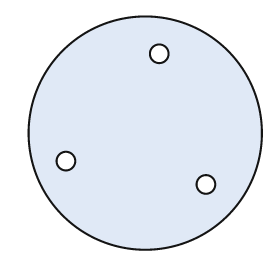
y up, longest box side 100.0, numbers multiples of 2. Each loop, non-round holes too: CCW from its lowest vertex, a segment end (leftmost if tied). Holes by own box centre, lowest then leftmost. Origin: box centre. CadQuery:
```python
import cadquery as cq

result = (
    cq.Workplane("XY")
    .moveTo(0.0, 0.0)
    .circle(50.0)
    .moveTo(26.0, -22.0)
    .circle(4.0)
    .moveTo(-34.0, -12.0)
    .circle(4.0)
    .moveTo(6.0, 34.0)
    .circle(4.0)
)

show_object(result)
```